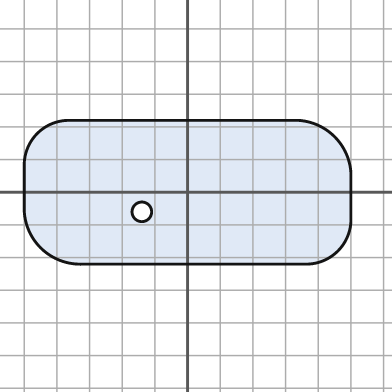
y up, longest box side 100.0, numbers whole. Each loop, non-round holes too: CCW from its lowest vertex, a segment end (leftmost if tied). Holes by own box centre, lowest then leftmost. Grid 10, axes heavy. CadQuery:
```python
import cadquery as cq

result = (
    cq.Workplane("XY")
    .moveTo(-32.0, -22.0)
    .lineTo(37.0, -22.0)
    .threePointArc((46.0, -18.0), (50.0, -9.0))
    .lineTo(50.0, 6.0)
    .threePointArc((45.0, 17.0), (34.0, 22.0))
    .lineTo(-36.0, 22.0)
    .threePointArc((-46.0, 18.0), (-50.0, 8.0))
    .lineTo(-50.0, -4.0)
    .threePointArc((-45.0, -17.0), (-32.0, -22.0))
    .close()
    .moveTo(-14.0, -6.0)
    .circle(3.0)
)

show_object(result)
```